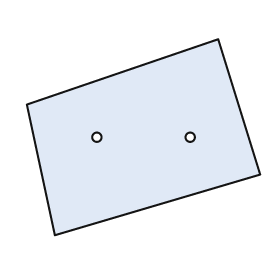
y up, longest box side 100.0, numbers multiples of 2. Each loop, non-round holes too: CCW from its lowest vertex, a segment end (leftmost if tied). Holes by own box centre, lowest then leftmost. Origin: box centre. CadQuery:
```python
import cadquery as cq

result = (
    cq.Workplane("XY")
    .moveTo(-38.0, -42.0)
    .lineTo(50.0, -16.0)
    .lineTo(32.0, 42.0)
    .lineTo(-50.0, 14.0)
    .close()
    .moveTo(-20.0, 0.0)
    .circle(2.0)
    .moveTo(20.0, 0.0)
    .circle(2.0)
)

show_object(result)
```